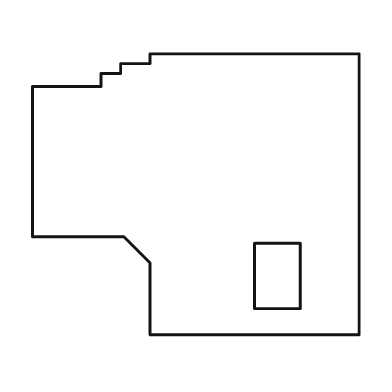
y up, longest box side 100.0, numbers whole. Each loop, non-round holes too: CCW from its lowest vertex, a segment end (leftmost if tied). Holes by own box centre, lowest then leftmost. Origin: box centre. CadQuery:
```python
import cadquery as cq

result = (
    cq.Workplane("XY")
    .moveTo(-14.0, -43.0)
    .lineTo(50.0, -43.0)
    .lineTo(50.0, 43.0)
    .lineTo(-14.0, 43.0)
    .lineTo(-14.0, 40.0)
    .lineTo(-23.0, 40.0)
    .lineTo(-23.0, 37.0)
    .lineTo(-29.0, 37.0)
    .lineTo(-29.0, 33.0)
    .lineTo(-50.0, 33.0)
    .lineTo(-50.0, -13.0)
    .lineTo(-22.0, -13.0)
    .lineTo(-14.0, -21.0)
    .close()
    .moveTo(18.0, -35.0)
    .lineTo(32.0, -35.0)
    .lineTo(32.0, -15.0)
    .lineTo(18.0, -15.0)
    .close()
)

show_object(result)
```